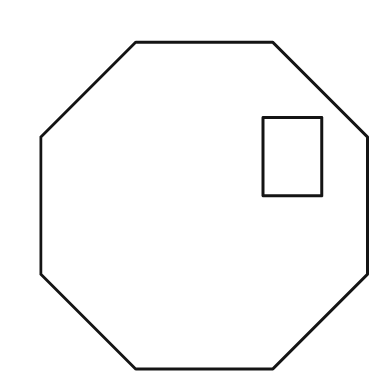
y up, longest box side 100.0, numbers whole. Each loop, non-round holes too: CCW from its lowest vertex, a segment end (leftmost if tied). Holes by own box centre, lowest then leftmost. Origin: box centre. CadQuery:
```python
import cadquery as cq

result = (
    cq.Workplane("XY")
    .moveTo(-21.0, -50.0)
    .lineTo(21.0, -50.0)
    .lineTo(50.0, -21.0)
    .lineTo(50.0, 21.0)
    .lineTo(21.0, 50.0)
    .lineTo(-21.0, 50.0)
    .lineTo(-50.0, 21.0)
    .lineTo(-50.0, -21.0)
    .close()
    .moveTo(18.0, 3.0)
    .lineTo(36.0, 3.0)
    .lineTo(36.0, 27.0)
    .lineTo(18.0, 27.0)
    .close()
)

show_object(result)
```